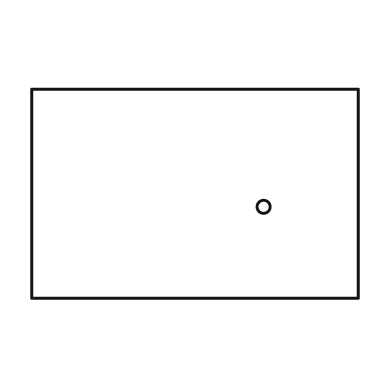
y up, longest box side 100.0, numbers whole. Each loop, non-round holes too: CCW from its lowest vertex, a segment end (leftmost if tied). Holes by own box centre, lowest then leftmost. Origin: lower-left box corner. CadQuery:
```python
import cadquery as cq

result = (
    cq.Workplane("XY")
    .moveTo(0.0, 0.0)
    .lineTo(100.0, 0.0)
    .lineTo(100.0, 64.0)
    .lineTo(0.0, 64.0)
    .close()
    .moveTo(71.0, 28.0)
    .circle(2.0)
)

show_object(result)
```